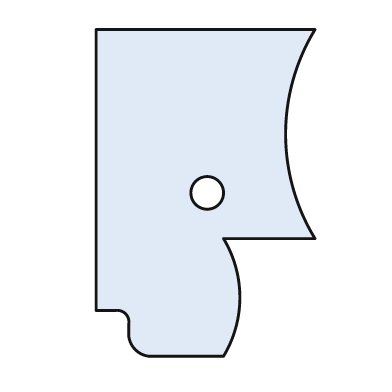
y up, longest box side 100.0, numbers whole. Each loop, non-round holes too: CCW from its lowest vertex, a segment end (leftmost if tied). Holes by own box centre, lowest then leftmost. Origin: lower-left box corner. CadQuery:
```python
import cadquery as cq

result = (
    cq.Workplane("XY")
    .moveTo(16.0, 0.0)
    .lineTo(39.0, 0.0)
    .threePointArc((44.0, 18.0), (39.0, 36.0))
    .lineTo(67.0, 36.0)
    .threePointArc((58.0, 68.0), (67.0, 100.0))
    .lineTo(0.0, 100.0)
    .lineTo(0.0, 14.0)
    .lineTo(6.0, 14.0)
    .threePointArc((9.0, 13.0), (10.0, 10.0))
    .lineTo(10.0, 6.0)
    .threePointArc((12.0, 2.0), (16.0, 0.0))
    .close()
    .moveTo(34.0, 50.0)
    .circle(5.0)
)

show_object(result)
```